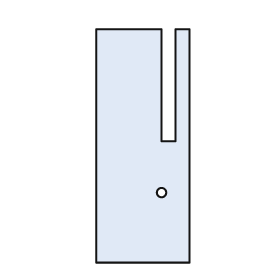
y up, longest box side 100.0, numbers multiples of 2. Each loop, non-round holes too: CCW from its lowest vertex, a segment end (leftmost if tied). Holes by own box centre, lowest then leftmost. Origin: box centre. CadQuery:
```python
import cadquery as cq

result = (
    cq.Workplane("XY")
    .moveTo(-20.0, -50.0)
    .lineTo(20.0, -50.0)
    .lineTo(20.0, 50.0)
    .lineTo(14.0, 50.0)
    .lineTo(14.0, 2.0)
    .lineTo(8.0, 2.0)
    .lineTo(8.0, 50.0)
    .lineTo(-20.0, 50.0)
    .close()
    .moveTo(8.0, -20.0)
    .circle(2.0)
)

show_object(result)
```